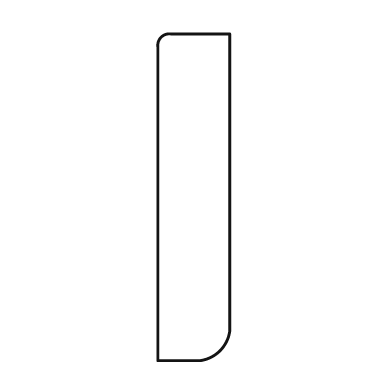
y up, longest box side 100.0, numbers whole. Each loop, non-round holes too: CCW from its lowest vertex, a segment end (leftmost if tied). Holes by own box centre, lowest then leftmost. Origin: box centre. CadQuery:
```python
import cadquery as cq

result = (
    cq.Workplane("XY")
    .moveTo(-11.0, -50.0)
    .lineTo(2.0, -50.0)
    .threePointArc((8.0, -47.0), (11.0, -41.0))
    .lineTo(11.0, 50.0)
    .lineTo(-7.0, 50.0)
    .threePointArc((-10.0, 49.0), (-11.0, 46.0))
    .close()
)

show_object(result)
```